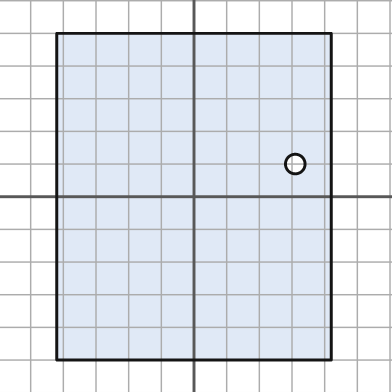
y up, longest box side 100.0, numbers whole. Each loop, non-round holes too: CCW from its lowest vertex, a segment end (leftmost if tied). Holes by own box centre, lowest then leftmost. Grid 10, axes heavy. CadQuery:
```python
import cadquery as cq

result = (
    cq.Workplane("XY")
    .moveTo(-42.0, -50.0)
    .lineTo(42.0, -50.0)
    .lineTo(42.0, 50.0)
    .lineTo(-42.0, 50.0)
    .close()
    .moveTo(31.0, 10.0)
    .circle(3.0)
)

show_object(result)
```